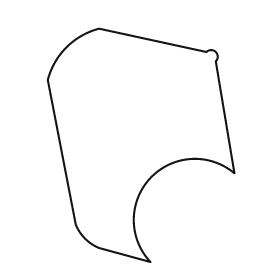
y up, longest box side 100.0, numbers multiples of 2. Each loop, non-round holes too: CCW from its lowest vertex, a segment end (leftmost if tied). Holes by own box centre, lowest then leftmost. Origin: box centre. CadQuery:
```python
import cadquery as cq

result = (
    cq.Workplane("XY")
    .moveTo(4.0, -50.0)
    .threePointArc((4.0, -14.0), (40.0, -12.0))
    .lineTo(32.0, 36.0)
    .threePointArc((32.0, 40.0), (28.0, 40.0))
    .lineTo(-18.0, 50.0)
    .threePointArc((-32.0, 42.0), (-40.0, 28.0))
    .lineTo(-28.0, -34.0)
    .threePointArc((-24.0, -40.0), (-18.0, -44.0))
    .close()
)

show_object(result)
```